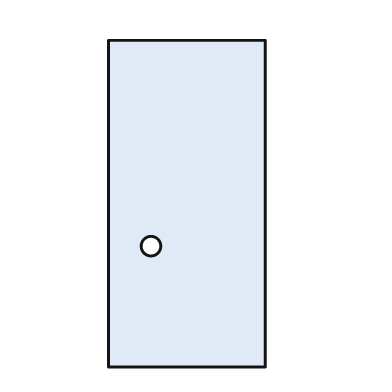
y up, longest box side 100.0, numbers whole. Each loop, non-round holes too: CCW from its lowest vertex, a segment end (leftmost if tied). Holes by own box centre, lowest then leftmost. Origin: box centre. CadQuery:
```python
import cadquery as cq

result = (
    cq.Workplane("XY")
    .moveTo(-24.0, -50.0)
    .lineTo(24.0, -50.0)
    .lineTo(24.0, 50.0)
    .lineTo(-24.0, 50.0)
    .close()
    .moveTo(-11.0, -13.0)
    .circle(3.0)
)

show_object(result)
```